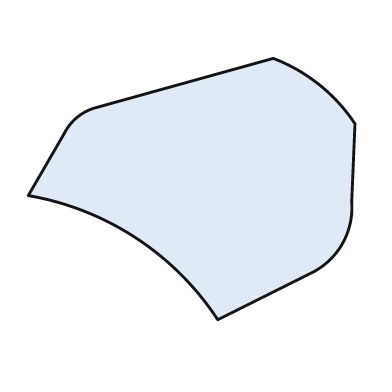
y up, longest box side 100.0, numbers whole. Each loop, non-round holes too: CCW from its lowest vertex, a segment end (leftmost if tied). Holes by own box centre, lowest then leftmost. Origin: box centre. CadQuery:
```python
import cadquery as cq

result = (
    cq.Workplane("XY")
    .moveTo(8.0, -40.0)
    .lineTo(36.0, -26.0)
    .threePointArc((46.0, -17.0), (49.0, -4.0))
    .lineTo(50.0, 20.0)
    .threePointArc((39.0, 32.0), (25.0, 40.0))
    .lineTo(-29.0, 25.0)
    .threePointArc((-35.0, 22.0), (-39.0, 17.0))
    .lineTo(-50.0, -2.0)
    .threePointArc((-17.0, -15.0), (8.0, -40.0))
    .close()
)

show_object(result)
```